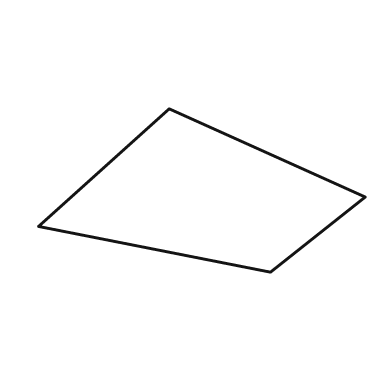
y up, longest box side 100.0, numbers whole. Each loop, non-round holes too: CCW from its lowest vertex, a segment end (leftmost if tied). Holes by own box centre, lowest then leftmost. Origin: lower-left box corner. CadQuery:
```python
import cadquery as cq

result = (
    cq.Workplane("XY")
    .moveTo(71.0, 0.0)
    .lineTo(100.0, 23.0)
    .lineTo(40.0, 50.0)
    .lineTo(0.0, 14.0)
    .close()
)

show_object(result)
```